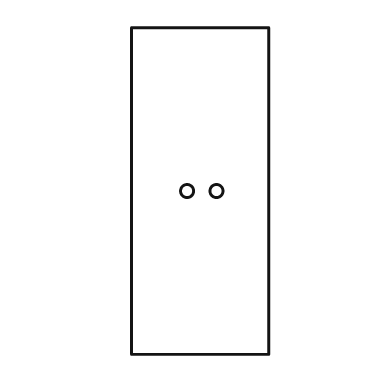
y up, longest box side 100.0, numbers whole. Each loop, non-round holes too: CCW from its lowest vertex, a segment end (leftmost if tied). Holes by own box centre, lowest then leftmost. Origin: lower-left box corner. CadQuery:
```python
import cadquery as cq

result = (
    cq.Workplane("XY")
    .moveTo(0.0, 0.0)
    .lineTo(42.0, 0.0)
    .lineTo(42.0, 100.0)
    .lineTo(0.0, 100.0)
    .close()
    .moveTo(17.0, 50.0)
    .circle(2.0)
    .moveTo(26.0, 50.0)
    .circle(2.0)
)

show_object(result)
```